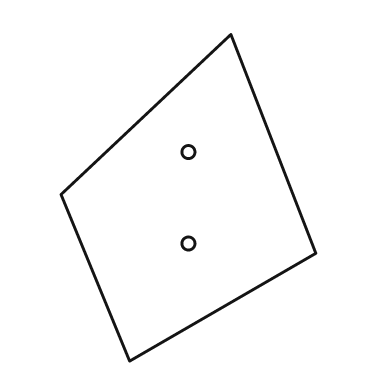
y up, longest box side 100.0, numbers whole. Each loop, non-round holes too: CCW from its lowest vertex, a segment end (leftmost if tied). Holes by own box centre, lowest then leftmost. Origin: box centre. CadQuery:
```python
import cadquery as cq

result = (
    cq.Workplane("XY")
    .moveTo(-18.0, -50.0)
    .lineTo(39.0, -17.0)
    .lineTo(13.0, 50.0)
    .lineTo(-39.0, 1.0)
    .close()
    .moveTo(0.0, -14.0)
    .circle(2.0)
    .moveTo(0.0, 14.0)
    .circle(2.0)
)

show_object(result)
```